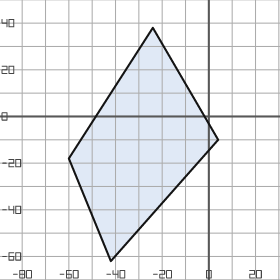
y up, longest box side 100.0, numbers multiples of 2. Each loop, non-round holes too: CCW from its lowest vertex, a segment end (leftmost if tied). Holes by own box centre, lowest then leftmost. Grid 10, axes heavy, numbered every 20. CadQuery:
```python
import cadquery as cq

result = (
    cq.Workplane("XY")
    .moveTo(-42.0, -62.0)
    .lineTo(4.0, -10.0)
    .lineTo(-24.0, 38.0)
    .lineTo(-60.0, -18.0)
    .close()
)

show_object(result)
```